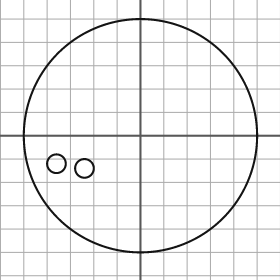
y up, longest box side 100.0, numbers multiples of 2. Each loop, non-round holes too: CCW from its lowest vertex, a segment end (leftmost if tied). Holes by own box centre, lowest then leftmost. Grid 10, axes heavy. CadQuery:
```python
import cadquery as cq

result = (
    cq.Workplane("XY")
    .moveTo(0.0, 0.0)
    .circle(50.0)
    .moveTo(-24.0, -14.0)
    .circle(4.0)
    .moveTo(-36.0, -12.0)
    .circle(4.0)
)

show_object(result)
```